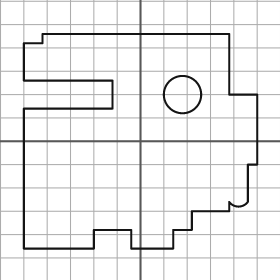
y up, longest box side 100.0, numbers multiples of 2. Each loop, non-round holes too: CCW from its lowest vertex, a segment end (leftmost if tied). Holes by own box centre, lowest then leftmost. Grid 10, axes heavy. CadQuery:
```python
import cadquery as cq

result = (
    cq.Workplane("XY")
    .moveTo(-50.0, -46.0)
    .lineTo(-20.0, -46.0)
    .lineTo(-20.0, -38.0)
    .lineTo(-4.0, -38.0)
    .lineTo(-4.0, -46.0)
    .lineTo(14.0, -46.0)
    .lineTo(14.0, -38.0)
    .lineTo(22.0, -38.0)
    .lineTo(22.0, -30.0)
    .lineTo(38.0, -30.0)
    .lineTo(38.0, -26.0)
    .threePointArc((42.0, -28.0), (46.0, -26.0))
    .lineTo(46.0, -10.0)
    .lineTo(50.0, -10.0)
    .lineTo(50.0, 20.0)
    .lineTo(38.0, 20.0)
    .lineTo(38.0, 46.0)
    .lineTo(-42.0, 46.0)
    .lineTo(-42.0, 42.0)
    .lineTo(-50.0, 42.0)
    .lineTo(-50.0, 26.0)
    .lineTo(-12.0, 26.0)
    .lineTo(-12.0, 14.0)
    .lineTo(-50.0, 14.0)
    .close()
    .moveTo(18.0, 20.0)
    .circle(8.0)
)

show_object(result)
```